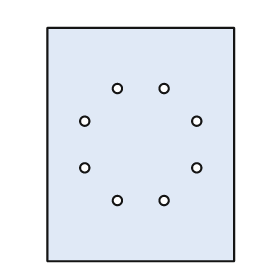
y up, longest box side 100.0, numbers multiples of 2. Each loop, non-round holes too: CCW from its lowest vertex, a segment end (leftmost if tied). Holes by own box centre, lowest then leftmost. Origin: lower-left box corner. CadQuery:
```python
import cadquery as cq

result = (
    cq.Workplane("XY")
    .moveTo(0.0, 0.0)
    .lineTo(80.0, 0.0)
    .lineTo(80.0, 100.0)
    .lineTo(0.0, 100.0)
    .close()
    .moveTo(30.0, 26.0)
    .circle(2.0)
    .moveTo(50.0, 26.0)
    .circle(2.0)
    .moveTo(16.0, 40.0)
    .circle(2.0)
    .moveTo(64.0, 40.0)
    .circle(2.0)
    .moveTo(16.0, 60.0)
    .circle(2.0)
    .moveTo(64.0, 60.0)
    .circle(2.0)
    .moveTo(30.0, 74.0)
    .circle(2.0)
    .moveTo(50.0, 74.0)
    .circle(2.0)
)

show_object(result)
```